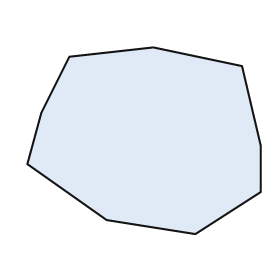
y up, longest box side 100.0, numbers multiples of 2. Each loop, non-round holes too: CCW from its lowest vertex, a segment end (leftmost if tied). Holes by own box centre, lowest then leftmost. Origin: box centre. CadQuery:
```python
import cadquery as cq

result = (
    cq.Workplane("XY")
    .moveTo(22.0, -40.0)
    .lineTo(50.0, -22.0)
    .lineTo(50.0, -2.0)
    .lineTo(42.0, 32.0)
    .lineTo(4.0, 40.0)
    .lineTo(-32.0, 36.0)
    .lineTo(-44.0, 12.0)
    .lineTo(-50.0, -10.0)
    .lineTo(-16.0, -34.0)
    .close()
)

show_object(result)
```